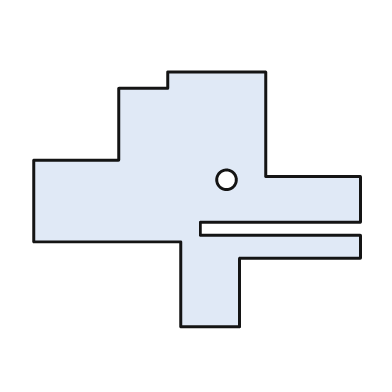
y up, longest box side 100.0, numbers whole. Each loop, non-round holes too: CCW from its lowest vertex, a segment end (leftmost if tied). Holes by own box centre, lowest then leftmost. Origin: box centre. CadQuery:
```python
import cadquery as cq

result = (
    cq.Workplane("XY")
    .moveTo(-5.0, -39.0)
    .lineTo(13.0, -39.0)
    .lineTo(13.0, -18.0)
    .lineTo(50.0, -18.0)
    .lineTo(50.0, -11.0)
    .lineTo(1.0, -11.0)
    .lineTo(1.0, -7.0)
    .lineTo(50.0, -7.0)
    .lineTo(50.0, 7.0)
    .lineTo(21.0, 7.0)
    .lineTo(21.0, 39.0)
    .lineTo(-9.0, 39.0)
    .lineTo(-9.0, 34.0)
    .lineTo(-24.0, 34.0)
    .lineTo(-24.0, 12.0)
    .lineTo(-50.0, 12.0)
    .lineTo(-50.0, -13.0)
    .lineTo(-5.0, -13.0)
    .close()
    .moveTo(9.0, 6.0)
    .circle(3.0)
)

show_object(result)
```